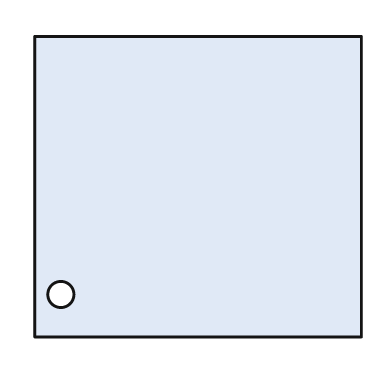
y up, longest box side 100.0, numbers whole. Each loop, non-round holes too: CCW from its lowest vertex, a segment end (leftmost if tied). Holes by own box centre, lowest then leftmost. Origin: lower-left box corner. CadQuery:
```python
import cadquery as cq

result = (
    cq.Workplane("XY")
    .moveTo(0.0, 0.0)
    .lineTo(100.0, 0.0)
    .lineTo(100.0, 92.0)
    .lineTo(0.0, 92.0)
    .close()
    .moveTo(8.0, 13.0)
    .circle(4.0)
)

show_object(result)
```